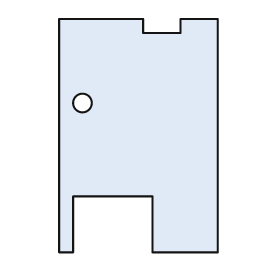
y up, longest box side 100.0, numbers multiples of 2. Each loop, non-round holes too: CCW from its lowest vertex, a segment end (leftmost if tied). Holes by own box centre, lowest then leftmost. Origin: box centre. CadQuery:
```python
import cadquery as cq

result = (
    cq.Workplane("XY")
    .moveTo(-34.0, -50.0)
    .lineTo(-28.0, -50.0)
    .lineTo(-28.0, -26.0)
    .lineTo(6.0, -26.0)
    .lineTo(6.0, -50.0)
    .lineTo(34.0, -50.0)
    .lineTo(34.0, 50.0)
    .lineTo(18.0, 50.0)
    .lineTo(18.0, 44.0)
    .lineTo(2.0, 44.0)
    .lineTo(2.0, 50.0)
    .lineTo(-34.0, 50.0)
    .close()
    .moveTo(-24.0, 14.0)
    .circle(4.0)
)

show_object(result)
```